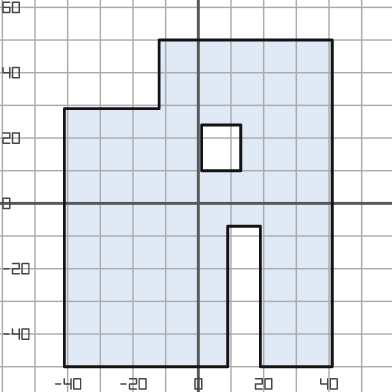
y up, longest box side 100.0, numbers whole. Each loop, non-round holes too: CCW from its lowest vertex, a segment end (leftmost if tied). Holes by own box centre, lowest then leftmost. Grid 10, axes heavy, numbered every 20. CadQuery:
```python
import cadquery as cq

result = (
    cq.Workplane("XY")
    .moveTo(-41.0, -50.0)
    .lineTo(9.0, -50.0)
    .lineTo(9.0, -7.0)
    .lineTo(19.0, -7.0)
    .lineTo(19.0, -50.0)
    .lineTo(41.0, -50.0)
    .lineTo(41.0, 50.0)
    .lineTo(-12.0, 50.0)
    .lineTo(-12.0, 29.0)
    .lineTo(-41.0, 29.0)
    .close()
    .moveTo(1.0, 10.0)
    .lineTo(13.0, 10.0)
    .lineTo(13.0, 24.0)
    .lineTo(1.0, 24.0)
    .close()
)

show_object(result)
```